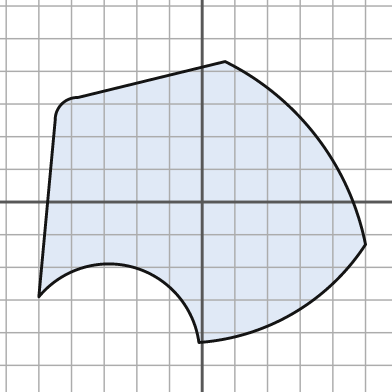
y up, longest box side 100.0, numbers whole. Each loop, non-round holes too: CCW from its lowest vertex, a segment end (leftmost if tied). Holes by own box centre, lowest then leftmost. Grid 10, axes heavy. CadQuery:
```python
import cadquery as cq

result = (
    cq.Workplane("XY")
    .moveTo(-1.0, -43.0)
    .threePointArc((28.0, -34.0), (50.0, -13.0))
    .threePointArc((35.0, 20.0), (7.0, 43.0))
    .lineTo(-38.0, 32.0)
    .threePointArc((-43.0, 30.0), (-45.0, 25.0))
    .lineTo(-50.0, -29.0)
    .threePointArc((-21.0, -20.0), (-1.0, -43.0))
    .close()
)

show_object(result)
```